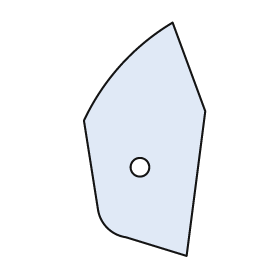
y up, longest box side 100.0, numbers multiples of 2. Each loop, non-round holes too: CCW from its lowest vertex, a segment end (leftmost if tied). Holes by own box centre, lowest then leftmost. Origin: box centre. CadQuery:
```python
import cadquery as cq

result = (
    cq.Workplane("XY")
    .moveTo(18.0, -50.0)
    .lineTo(26.0, 12.0)
    .lineTo(12.0, 50.0)
    .threePointArc((-10.0, 32.0), (-26.0, 8.0))
    .lineTo(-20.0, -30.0)
    .threePointArc((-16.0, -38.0), (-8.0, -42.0))
    .close()
    .moveTo(-2.0, -12.0)
    .circle(4.0)
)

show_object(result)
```